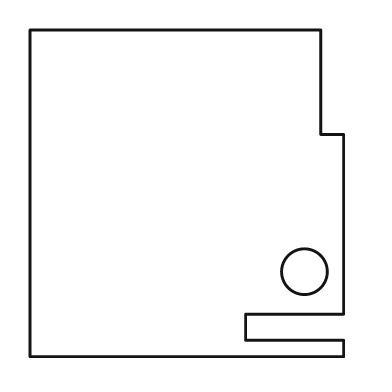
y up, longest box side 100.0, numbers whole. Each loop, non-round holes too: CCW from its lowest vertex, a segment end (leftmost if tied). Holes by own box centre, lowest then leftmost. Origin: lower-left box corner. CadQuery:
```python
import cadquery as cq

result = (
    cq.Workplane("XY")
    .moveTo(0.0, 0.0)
    .lineTo(96.0, 0.0)
    .lineTo(96.0, 5.0)
    .lineTo(66.0, 5.0)
    .lineTo(66.0, 13.0)
    .lineTo(96.0, 13.0)
    .lineTo(96.0, 68.0)
    .lineTo(89.0, 68.0)
    .lineTo(89.0, 100.0)
    .lineTo(0.0, 100.0)
    .close()
    .moveTo(84.0, 26.0)
    .circle(7.0)
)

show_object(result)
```